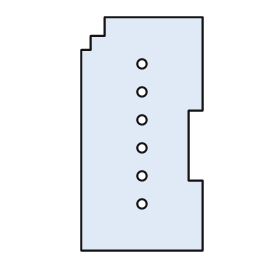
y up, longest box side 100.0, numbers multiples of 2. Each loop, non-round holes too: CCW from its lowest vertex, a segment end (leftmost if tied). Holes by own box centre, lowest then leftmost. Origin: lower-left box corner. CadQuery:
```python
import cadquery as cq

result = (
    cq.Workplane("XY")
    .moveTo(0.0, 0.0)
    .lineTo(52.0, 0.0)
    .lineTo(52.0, 30.0)
    .lineTo(46.0, 30.0)
    .lineTo(46.0, 60.0)
    .lineTo(52.0, 60.0)
    .lineTo(52.0, 100.0)
    .lineTo(10.0, 100.0)
    .lineTo(10.0, 92.0)
    .lineTo(4.0, 92.0)
    .lineTo(4.0, 86.0)
    .lineTo(0.0, 86.0)
    .close()
    .moveTo(26.0, 20.0)
    .circle(2.0)
    .moveTo(26.0, 32.0)
    .circle(2.0)
    .moveTo(26.0, 44.0)
    .circle(2.0)
    .moveTo(26.0, 56.0)
    .circle(2.0)
    .moveTo(26.0, 68.0)
    .circle(2.0)
    .moveTo(26.0, 80.0)
    .circle(2.0)
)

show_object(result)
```